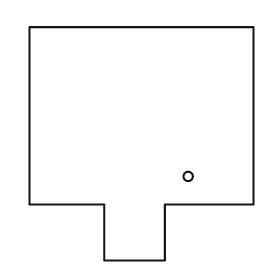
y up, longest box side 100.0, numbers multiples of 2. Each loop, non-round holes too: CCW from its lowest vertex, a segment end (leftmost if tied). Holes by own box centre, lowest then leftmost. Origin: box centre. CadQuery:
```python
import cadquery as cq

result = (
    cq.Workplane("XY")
    .moveTo(-16.0, -50.0)
    .lineTo(10.0, -50.0)
    .lineTo(10.0, -26.0)
    .lineTo(48.0, -26.0)
    .lineTo(48.0, 50.0)
    .lineTo(-48.0, 50.0)
    .lineTo(-48.0, -26.0)
    .lineTo(-16.0, -26.0)
    .close()
    .moveTo(20.0, -14.0)
    .circle(2.0)
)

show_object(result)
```